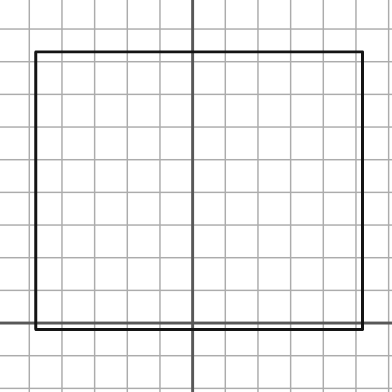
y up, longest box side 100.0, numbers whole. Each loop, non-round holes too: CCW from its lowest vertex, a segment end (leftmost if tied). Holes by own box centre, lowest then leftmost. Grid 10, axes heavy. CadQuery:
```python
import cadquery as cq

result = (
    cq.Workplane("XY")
    .moveTo(-48.0, -2.0)
    .lineTo(52.0, -2.0)
    .lineTo(52.0, 83.0)
    .lineTo(-48.0, 83.0)
    .close()
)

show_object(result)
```